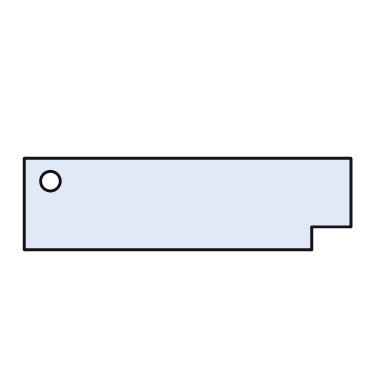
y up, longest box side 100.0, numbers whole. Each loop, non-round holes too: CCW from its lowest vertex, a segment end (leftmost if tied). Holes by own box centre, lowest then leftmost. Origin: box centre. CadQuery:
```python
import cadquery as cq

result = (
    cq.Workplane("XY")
    .moveTo(-50.0, -14.0)
    .lineTo(38.0, -14.0)
    .lineTo(38.0, -7.0)
    .lineTo(50.0, -7.0)
    .lineTo(50.0, 14.0)
    .lineTo(-50.0, 14.0)
    .close()
    .moveTo(-42.0, 7.0)
    .circle(3.0)
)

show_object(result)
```